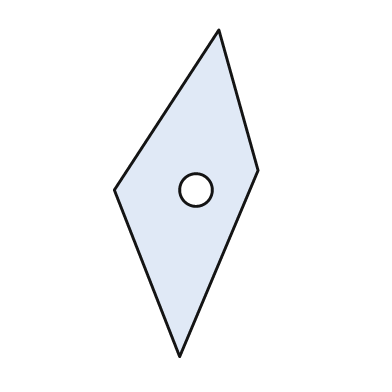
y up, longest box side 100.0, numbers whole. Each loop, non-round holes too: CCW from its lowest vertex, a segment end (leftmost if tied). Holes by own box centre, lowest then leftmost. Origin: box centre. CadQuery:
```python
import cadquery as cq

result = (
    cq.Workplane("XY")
    .moveTo(-2.0, -50.0)
    .lineTo(22.0, 7.0)
    .lineTo(10.0, 50.0)
    .lineTo(-22.0, 1.0)
    .close()
    .moveTo(3.0, 1.0)
    .circle(5.0)
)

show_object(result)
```